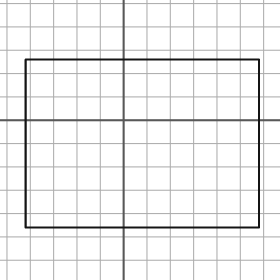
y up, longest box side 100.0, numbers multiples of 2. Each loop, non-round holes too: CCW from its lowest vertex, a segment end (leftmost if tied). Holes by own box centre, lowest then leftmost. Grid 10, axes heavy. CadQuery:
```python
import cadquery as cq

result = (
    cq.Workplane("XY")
    .moveTo(-42.0, -46.0)
    .lineTo(58.0, -46.0)
    .lineTo(58.0, 26.0)
    .lineTo(-42.0, 26.0)
    .close()
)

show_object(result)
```